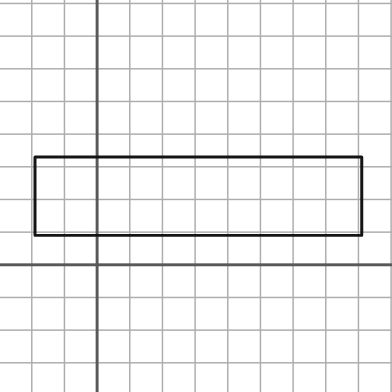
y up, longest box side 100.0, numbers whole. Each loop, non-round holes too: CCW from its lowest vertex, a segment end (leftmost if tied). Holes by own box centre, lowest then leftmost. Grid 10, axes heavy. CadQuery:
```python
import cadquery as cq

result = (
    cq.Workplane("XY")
    .moveTo(-19.0, 9.0)
    .lineTo(81.0, 9.0)
    .lineTo(81.0, 33.0)
    .lineTo(-19.0, 33.0)
    .close()
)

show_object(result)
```